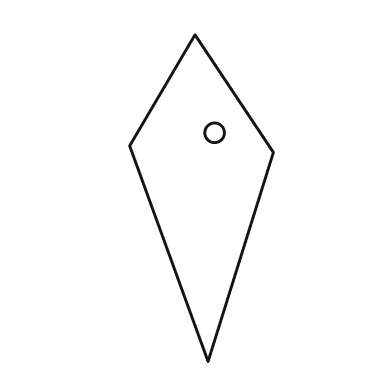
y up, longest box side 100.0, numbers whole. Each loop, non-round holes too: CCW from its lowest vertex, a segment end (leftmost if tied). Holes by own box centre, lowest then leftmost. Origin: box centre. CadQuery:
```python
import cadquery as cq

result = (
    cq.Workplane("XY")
    .moveTo(2.0, -50.0)
    .lineTo(22.0, 14.0)
    .lineTo(-2.0, 50.0)
    .lineTo(-22.0, 16.0)
    .close()
    .moveTo(4.0, 20.0)
    .circle(3.0)
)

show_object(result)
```